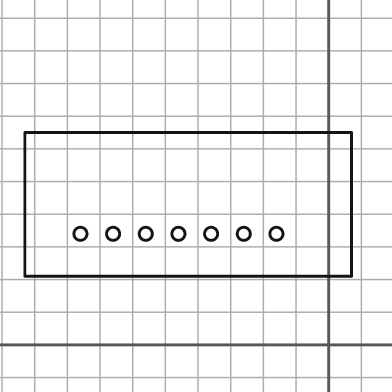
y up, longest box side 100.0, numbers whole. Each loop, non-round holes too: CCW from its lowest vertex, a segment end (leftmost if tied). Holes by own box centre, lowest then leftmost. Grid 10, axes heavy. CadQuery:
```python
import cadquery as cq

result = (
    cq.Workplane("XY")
    .moveTo(-93.0, 21.0)
    .lineTo(7.0, 21.0)
    .lineTo(7.0, 65.0)
    .lineTo(-93.0, 65.0)
    .close()
    .moveTo(-76.0, 34.0)
    .circle(2.0)
    .moveTo(-66.0, 34.0)
    .circle(2.0)
    .moveTo(-56.0, 34.0)
    .circle(2.0)
    .moveTo(-46.0, 34.0)
    .circle(2.0)
    .moveTo(-36.0, 34.0)
    .circle(2.0)
    .moveTo(-26.0, 34.0)
    .circle(2.0)
    .moveTo(-16.0, 34.0)
    .circle(2.0)
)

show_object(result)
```